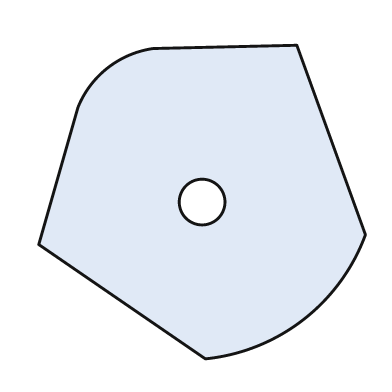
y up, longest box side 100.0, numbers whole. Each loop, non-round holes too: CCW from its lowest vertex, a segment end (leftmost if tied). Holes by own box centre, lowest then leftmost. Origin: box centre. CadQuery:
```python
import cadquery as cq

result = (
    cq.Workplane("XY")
    .moveTo(1.0, -48.0)
    .threePointArc((31.0, -36.0), (50.0, -10.0))
    .lineTo(29.0, 48.0)
    .lineTo(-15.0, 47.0)
    .threePointArc((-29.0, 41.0), (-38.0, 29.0))
    .lineTo(-50.0, -13.0)
    .close()
    .moveTo(0.0, 0.0)
    .circle(7.0)
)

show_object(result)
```